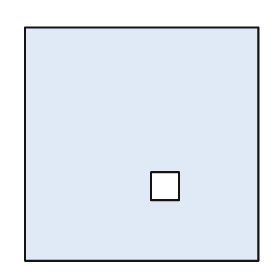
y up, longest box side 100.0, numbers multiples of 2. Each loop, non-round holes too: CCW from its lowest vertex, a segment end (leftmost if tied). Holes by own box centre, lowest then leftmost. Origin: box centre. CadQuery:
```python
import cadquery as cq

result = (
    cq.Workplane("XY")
    .moveTo(-50.0, -50.0)
    .lineTo(50.0, -50.0)
    .lineTo(50.0, 50.0)
    .lineTo(-50.0, 50.0)
    .close()
    .moveTo(4.0, -24.0)
    .lineTo(16.0, -24.0)
    .lineTo(16.0, -12.0)
    .lineTo(4.0, -12.0)
    .close()
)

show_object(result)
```